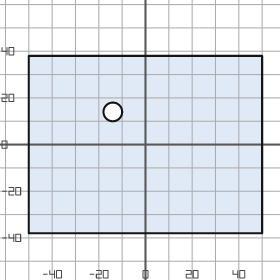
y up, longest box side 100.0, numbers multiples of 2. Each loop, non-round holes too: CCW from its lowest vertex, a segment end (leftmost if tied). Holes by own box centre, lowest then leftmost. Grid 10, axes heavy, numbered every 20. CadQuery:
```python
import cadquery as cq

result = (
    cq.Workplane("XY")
    .moveTo(-50.0, -38.0)
    .lineTo(50.0, -38.0)
    .lineTo(50.0, 38.0)
    .lineTo(-50.0, 38.0)
    .close()
    .moveTo(-14.0, 14.0)
    .circle(4.0)
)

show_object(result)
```